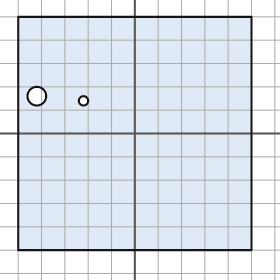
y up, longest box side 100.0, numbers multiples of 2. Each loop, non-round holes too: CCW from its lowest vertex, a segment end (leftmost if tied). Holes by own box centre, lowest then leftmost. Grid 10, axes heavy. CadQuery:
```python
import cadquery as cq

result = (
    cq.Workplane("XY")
    .moveTo(-50.0, -50.0)
    .lineTo(50.0, -50.0)
    .lineTo(50.0, 50.0)
    .lineTo(-50.0, 50.0)
    .close()
    .moveTo(-22.0, 14.0)
    .circle(2.0)
    .moveTo(-42.0, 16.0)
    .circle(4.0)
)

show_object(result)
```